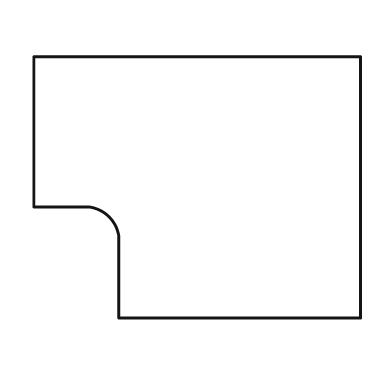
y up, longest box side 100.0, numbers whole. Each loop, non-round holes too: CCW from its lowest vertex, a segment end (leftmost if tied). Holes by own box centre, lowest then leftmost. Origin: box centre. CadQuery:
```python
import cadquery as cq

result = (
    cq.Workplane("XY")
    .moveTo(-24.0, -40.0)
    .lineTo(50.0, -40.0)
    .lineTo(50.0, 40.0)
    .lineTo(-50.0, 40.0)
    .lineTo(-50.0, -6.0)
    .lineTo(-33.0, -6.0)
    .threePointArc((-27.0, -9.0), (-24.0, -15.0))
    .close()
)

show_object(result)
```